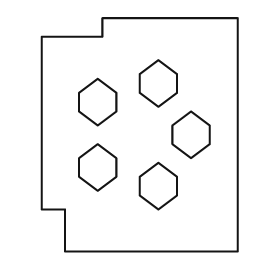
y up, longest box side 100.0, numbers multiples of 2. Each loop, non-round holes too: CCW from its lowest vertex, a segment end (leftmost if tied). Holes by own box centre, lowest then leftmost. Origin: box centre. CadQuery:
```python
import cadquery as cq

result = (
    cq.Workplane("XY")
    .moveTo(-32.0, -50.0)
    .lineTo(42.0, -50.0)
    .lineTo(42.0, 50.0)
    .lineTo(-16.0, 50.0)
    .lineTo(-16.0, 42.0)
    .lineTo(-42.0, 42.0)
    .lineTo(-42.0, -32.0)
    .lineTo(-32.0, -32.0)
    .close()
    .moveTo(8.0, -32.0)
    .lineTo(16.0, -26.0)
    .lineTo(16.0, -18.0)
    .lineTo(8.0, -12.0)
    .lineTo(0.0, -18.0)
    .lineTo(0.0, -26.0)
    .close()
    .moveTo(-18.0, -24.0)
    .lineTo(-10.0, -18.0)
    .lineTo(-10.0, -10.0)
    .lineTo(-18.0, -4.0)
    .lineTo(-26.0, -10.0)
    .lineTo(-26.0, -18.0)
    .close()
    .moveTo(22.0, -10.0)
    .lineTo(30.0, -4.0)
    .lineTo(30.0, 4.0)
    .lineTo(22.0, 10.0)
    .lineTo(14.0, 4.0)
    .lineTo(14.0, -4.0)
    .close()
    .moveTo(-18.0, 4.0)
    .lineTo(-10.0, 10.0)
    .lineTo(-10.0, 18.0)
    .lineTo(-18.0, 24.0)
    .lineTo(-26.0, 18.0)
    .lineTo(-26.0, 10.0)
    .close()
    .moveTo(8.0, 12.0)
    .lineTo(16.0, 18.0)
    .lineTo(16.0, 26.0)
    .lineTo(8.0, 32.0)
    .lineTo(0.0, 26.0)
    .lineTo(0.0, 18.0)
    .close()
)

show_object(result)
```